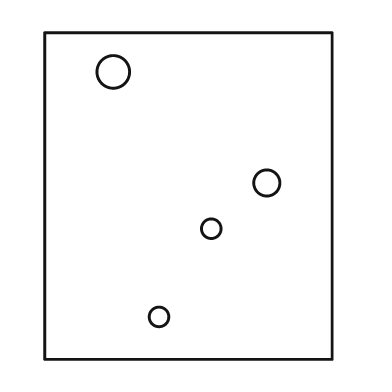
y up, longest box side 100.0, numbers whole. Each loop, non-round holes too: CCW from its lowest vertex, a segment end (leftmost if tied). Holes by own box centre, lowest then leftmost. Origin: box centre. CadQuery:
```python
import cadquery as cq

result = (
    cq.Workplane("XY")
    .moveTo(-44.0, -50.0)
    .lineTo(44.0, -50.0)
    .lineTo(44.0, 50.0)
    .lineTo(-44.0, 50.0)
    .close()
    .moveTo(-9.0, -37.0)
    .circle(3.0)
    .moveTo(7.0, -10.0)
    .circle(3.0)
    .moveTo(24.0, 4.0)
    .circle(4.0)
    .moveTo(-23.0, 38.0)
    .circle(5.0)
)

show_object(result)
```